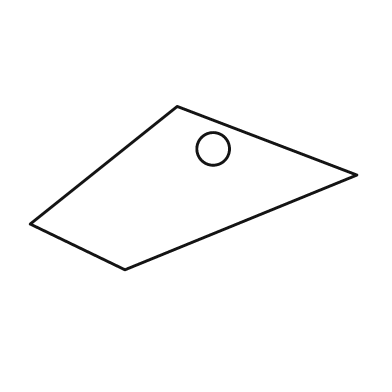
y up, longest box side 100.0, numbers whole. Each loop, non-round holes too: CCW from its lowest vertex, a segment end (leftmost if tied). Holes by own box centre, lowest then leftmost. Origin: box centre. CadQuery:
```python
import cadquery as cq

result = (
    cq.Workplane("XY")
    .moveTo(-21.0, -25.0)
    .lineTo(50.0, 4.0)
    .lineTo(-5.0, 25.0)
    .lineTo(-50.0, -11.0)
    .close()
    .moveTo(6.0, 12.0)
    .circle(5.0)
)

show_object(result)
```